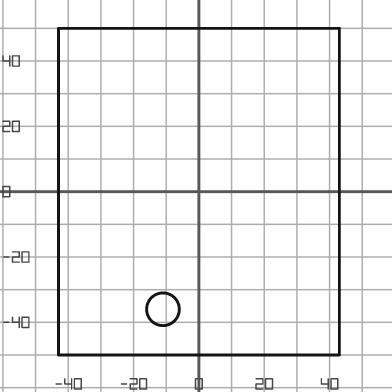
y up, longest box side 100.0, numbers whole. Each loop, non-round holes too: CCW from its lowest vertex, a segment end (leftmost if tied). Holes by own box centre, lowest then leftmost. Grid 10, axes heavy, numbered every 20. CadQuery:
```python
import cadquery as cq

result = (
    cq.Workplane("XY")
    .moveTo(-43.0, -50.0)
    .lineTo(43.0, -50.0)
    .lineTo(43.0, 50.0)
    .lineTo(-43.0, 50.0)
    .close()
    .moveTo(-11.0, -36.0)
    .circle(5.0)
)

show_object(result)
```